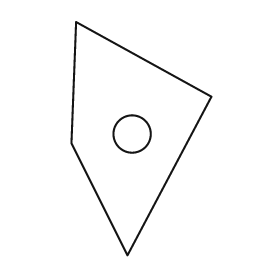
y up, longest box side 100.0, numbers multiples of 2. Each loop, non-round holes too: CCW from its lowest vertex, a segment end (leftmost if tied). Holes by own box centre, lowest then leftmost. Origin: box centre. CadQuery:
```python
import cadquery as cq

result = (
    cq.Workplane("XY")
    .moveTo(-6.0, -50.0)
    .lineTo(30.0, 18.0)
    .lineTo(-28.0, 50.0)
    .lineTo(-30.0, -2.0)
    .close()
    .moveTo(-4.0, 2.0)
    .circle(8.0)
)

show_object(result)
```